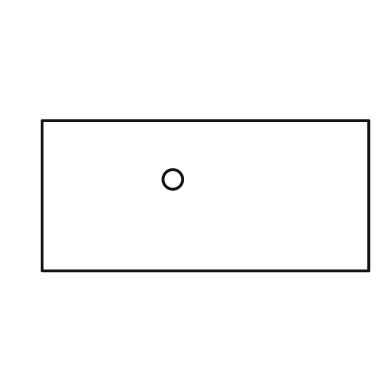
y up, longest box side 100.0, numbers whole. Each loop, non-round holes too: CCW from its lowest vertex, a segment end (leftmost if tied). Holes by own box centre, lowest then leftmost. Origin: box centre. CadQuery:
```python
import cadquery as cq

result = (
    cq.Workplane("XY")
    .moveTo(-50.0, -23.0)
    .lineTo(50.0, -23.0)
    .lineTo(50.0, 23.0)
    .lineTo(-50.0, 23.0)
    .close()
    .moveTo(-10.0, 5.0)
    .circle(3.0)
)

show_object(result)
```